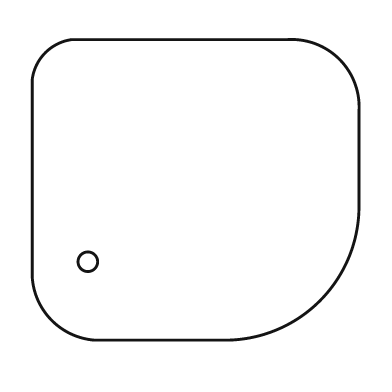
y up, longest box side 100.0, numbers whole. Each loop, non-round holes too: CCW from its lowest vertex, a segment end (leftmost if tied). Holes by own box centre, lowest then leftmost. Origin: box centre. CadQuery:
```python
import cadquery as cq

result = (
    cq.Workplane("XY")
    .moveTo(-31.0, -46.0)
    .lineTo(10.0, -46.0)
    .threePointArc((38.0, -34.0), (50.0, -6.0))
    .lineTo(50.0, 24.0)
    .threePointArc((44.0, 40.0), (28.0, 46.0))
    .lineTo(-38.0, 46.0)
    .threePointArc((-46.0, 42.0), (-50.0, 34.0))
    .lineTo(-50.0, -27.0)
    .threePointArc((-44.0, -40.0), (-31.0, -46.0))
    .close()
    .moveTo(-33.0, -22.0)
    .circle(3.0)
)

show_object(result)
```